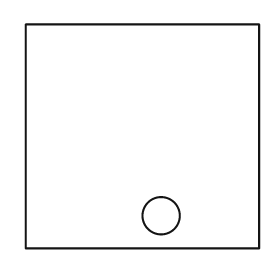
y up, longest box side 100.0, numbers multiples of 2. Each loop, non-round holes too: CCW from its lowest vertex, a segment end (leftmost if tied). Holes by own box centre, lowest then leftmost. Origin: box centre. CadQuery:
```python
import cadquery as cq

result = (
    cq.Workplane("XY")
    .moveTo(-50.0, -48.0)
    .lineTo(50.0, -48.0)
    .lineTo(50.0, 48.0)
    .lineTo(-50.0, 48.0)
    .close()
    .moveTo(8.0, -34.0)
    .circle(8.0)
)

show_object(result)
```